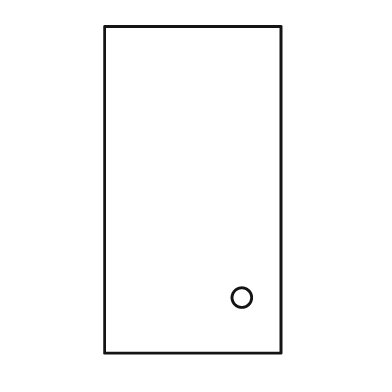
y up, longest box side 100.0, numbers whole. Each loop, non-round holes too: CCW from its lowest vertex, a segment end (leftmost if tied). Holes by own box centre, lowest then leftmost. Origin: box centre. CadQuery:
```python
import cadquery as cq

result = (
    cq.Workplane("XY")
    .moveTo(-27.0, -50.0)
    .lineTo(27.0, -50.0)
    .lineTo(27.0, 50.0)
    .lineTo(-27.0, 50.0)
    .close()
    .moveTo(15.0, -33.0)
    .circle(3.0)
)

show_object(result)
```